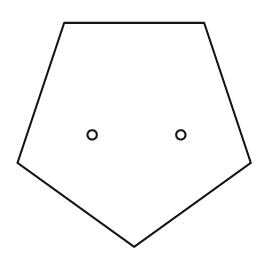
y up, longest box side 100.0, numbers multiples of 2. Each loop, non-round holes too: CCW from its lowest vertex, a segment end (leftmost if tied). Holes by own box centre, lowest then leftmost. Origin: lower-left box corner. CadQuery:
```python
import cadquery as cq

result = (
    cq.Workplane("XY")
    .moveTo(50.0, 0.0)
    .lineTo(100.0, 36.0)
    .lineTo(80.0, 96.0)
    .lineTo(20.0, 96.0)
    .lineTo(0.0, 36.0)
    .close()
    .moveTo(32.0, 48.0)
    .circle(2.0)
    .moveTo(70.0, 48.0)
    .circle(2.0)
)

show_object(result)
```